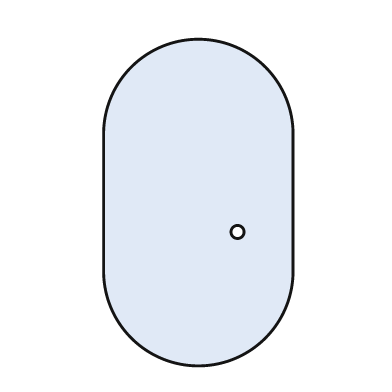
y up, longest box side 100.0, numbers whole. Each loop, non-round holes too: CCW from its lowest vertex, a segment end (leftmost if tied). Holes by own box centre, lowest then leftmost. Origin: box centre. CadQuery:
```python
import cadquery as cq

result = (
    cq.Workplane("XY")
    .moveTo(-29.0, -21.0)
    .threePointArc((0.0, -50.0), (29.0, -21.0))
    .lineTo(29.0, 21.0)
    .threePointArc((0.0, 50.0), (-29.0, 21.0))
    .close()
    .moveTo(12.0, -9.0)
    .circle(2.0)
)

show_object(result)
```